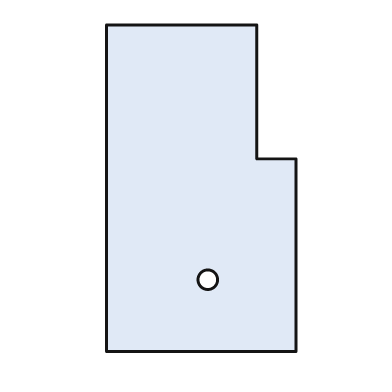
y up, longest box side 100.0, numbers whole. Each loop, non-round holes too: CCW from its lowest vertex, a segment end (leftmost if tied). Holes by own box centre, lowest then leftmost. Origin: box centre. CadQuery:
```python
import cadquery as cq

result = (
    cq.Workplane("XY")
    .moveTo(-29.0, -50.0)
    .lineTo(29.0, -50.0)
    .lineTo(29.0, 9.0)
    .lineTo(17.0, 9.0)
    .lineTo(17.0, 50.0)
    .lineTo(-29.0, 50.0)
    .close()
    .moveTo(2.0, -28.0)
    .circle(3.0)
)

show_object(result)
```